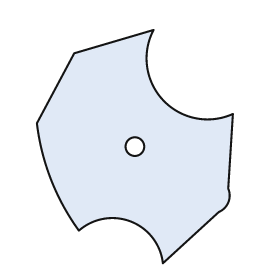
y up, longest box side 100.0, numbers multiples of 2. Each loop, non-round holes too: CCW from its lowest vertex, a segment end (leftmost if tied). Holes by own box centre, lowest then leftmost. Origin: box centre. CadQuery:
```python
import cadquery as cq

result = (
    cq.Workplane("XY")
    .moveTo(12.0, -50.0)
    .lineTo(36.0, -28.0)
    .threePointArc((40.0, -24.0), (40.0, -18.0))
    .lineTo(42.0, 14.0)
    .threePointArc((12.0, 20.0), (8.0, 50.0))
    .lineTo(-26.0, 40.0)
    .lineTo(-42.0, 10.0)
    .threePointArc((-36.0, -14.0), (-24.0, -36.0))
    .threePointArc((-2.0, -32.0), (12.0, -50.0))
    .close()
    .moveTo(0.0, 0.0)
    .circle(4.0)
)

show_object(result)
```